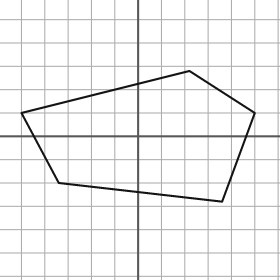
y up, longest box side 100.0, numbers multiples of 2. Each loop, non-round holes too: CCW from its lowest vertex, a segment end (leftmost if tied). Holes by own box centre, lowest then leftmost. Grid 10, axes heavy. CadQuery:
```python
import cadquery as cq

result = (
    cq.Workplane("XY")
    .moveTo(36.0, -28.0)
    .lineTo(50.0, 10.0)
    .lineTo(22.0, 28.0)
    .lineTo(-50.0, 10.0)
    .lineTo(-34.0, -20.0)
    .close()
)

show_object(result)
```